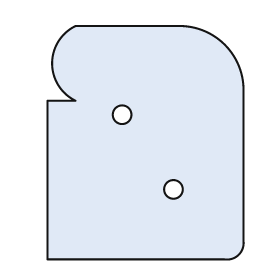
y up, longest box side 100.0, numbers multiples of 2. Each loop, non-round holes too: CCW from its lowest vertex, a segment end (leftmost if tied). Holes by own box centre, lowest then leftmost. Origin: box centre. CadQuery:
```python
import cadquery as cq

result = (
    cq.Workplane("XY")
    .moveTo(-42.0, -50.0)
    .lineTo(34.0, -50.0)
    .threePointArc((40.0, -48.0), (42.0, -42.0))
    .lineTo(42.0, 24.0)
    .threePointArc((34.0, 42.0), (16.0, 50.0))
    .lineTo(-30.0, 50.0)
    .threePointArc((-40.0, 34.0), (-30.0, 18.0))
    .lineTo(-42.0, 18.0)
    .close()
    .moveTo(12.0, -20.0)
    .circle(4.0)
    .moveTo(-10.0, 12.0)
    .circle(4.0)
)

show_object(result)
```